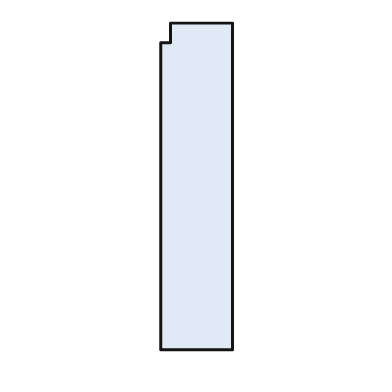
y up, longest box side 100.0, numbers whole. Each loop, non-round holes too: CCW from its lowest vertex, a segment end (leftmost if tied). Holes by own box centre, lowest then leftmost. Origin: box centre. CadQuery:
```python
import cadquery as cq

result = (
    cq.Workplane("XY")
    .moveTo(-11.0, -50.0)
    .lineTo(11.0, -50.0)
    .lineTo(11.0, 50.0)
    .lineTo(-8.0, 50.0)
    .lineTo(-8.0, 44.0)
    .lineTo(-11.0, 44.0)
    .close()
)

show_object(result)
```